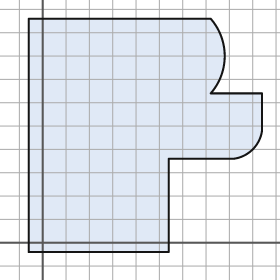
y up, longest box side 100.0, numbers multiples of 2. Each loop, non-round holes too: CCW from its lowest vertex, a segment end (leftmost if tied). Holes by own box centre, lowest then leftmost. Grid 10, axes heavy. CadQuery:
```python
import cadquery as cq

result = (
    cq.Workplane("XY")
    .moveTo(-6.0, -4.0)
    .lineTo(54.0, -4.0)
    .lineTo(54.0, 36.0)
    .lineTo(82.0, 36.0)
    .threePointArc((90.0, 40.0), (94.0, 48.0))
    .lineTo(94.0, 64.0)
    .lineTo(72.0, 64.0)
    .threePointArc((78.0, 80.0), (72.0, 96.0))
    .lineTo(-6.0, 96.0)
    .close()
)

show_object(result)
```